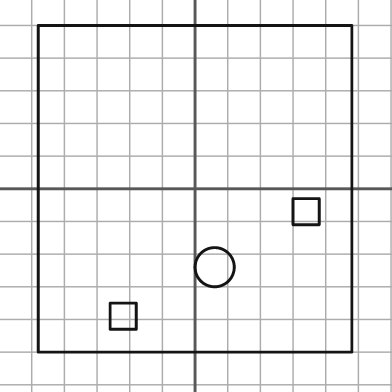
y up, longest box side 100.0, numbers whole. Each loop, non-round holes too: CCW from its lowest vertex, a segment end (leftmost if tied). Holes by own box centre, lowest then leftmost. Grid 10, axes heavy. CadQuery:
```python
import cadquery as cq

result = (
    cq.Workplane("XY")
    .moveTo(-48.0, -50.0)
    .lineTo(48.0, -50.0)
    .lineTo(48.0, 50.0)
    .lineTo(-48.0, 50.0)
    .close()
    .moveTo(-26.0, -43.0)
    .lineTo(-18.0, -43.0)
    .lineTo(-18.0, -35.0)
    .lineTo(-26.0, -35.0)
    .close()
    .moveTo(6.0, -24.0)
    .circle(6.0)
    .moveTo(30.0, -11.0)
    .lineTo(38.0, -11.0)
    .lineTo(38.0, -3.0)
    .lineTo(30.0, -3.0)
    .close()
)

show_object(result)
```